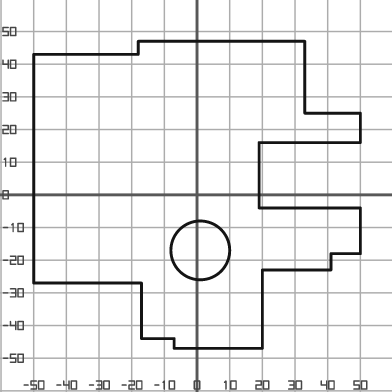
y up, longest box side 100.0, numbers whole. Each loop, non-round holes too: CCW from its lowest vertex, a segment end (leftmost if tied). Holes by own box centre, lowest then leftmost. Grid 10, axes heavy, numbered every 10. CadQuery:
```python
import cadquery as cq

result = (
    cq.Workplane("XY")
    .moveTo(-7.0, -47.0)
    .lineTo(20.0, -47.0)
    .lineTo(20.0, -23.0)
    .lineTo(41.0, -23.0)
    .lineTo(41.0, -18.0)
    .lineTo(50.0, -18.0)
    .lineTo(50.0, -4.0)
    .lineTo(19.0, -4.0)
    .lineTo(19.0, 16.0)
    .lineTo(50.0, 16.0)
    .lineTo(50.0, 25.0)
    .lineTo(33.0, 25.0)
    .lineTo(33.0, 47.0)
    .lineTo(-18.0, 47.0)
    .lineTo(-18.0, 43.0)
    .lineTo(-50.0, 43.0)
    .lineTo(-50.0, -27.0)
    .lineTo(-17.0, -27.0)
    .lineTo(-17.0, -44.0)
    .lineTo(-7.0, -44.0)
    .close()
    .moveTo(1.0, -17.0)
    .circle(9.0)
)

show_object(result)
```